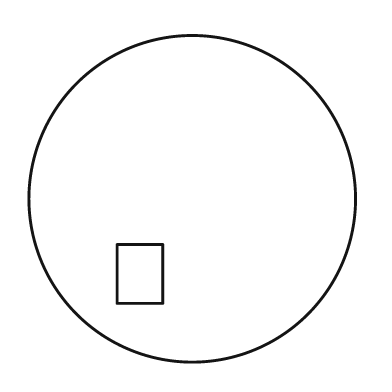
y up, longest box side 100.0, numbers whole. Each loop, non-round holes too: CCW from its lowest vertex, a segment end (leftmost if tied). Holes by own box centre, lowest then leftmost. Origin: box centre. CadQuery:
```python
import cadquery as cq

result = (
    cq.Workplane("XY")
    .moveTo(0.0, 0.0)
    .circle(50.0)
    .moveTo(-23.0, -32.0)
    .lineTo(-9.0, -32.0)
    .lineTo(-9.0, -14.0)
    .lineTo(-23.0, -14.0)
    .close()
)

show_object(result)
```